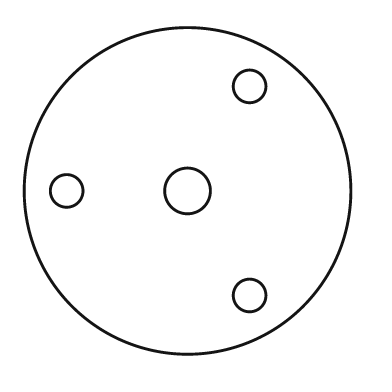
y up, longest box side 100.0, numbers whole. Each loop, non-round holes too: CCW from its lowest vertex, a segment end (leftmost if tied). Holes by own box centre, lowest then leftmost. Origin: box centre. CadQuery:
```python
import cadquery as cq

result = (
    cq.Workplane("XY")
    .moveTo(0.0, 0.0)
    .circle(50.0)
    .moveTo(19.0, -32.0)
    .circle(5.0)
    .moveTo(-37.0, 0.0)
    .circle(5.0)
    .moveTo(0.0, 0.0)
    .circle(7.0)
    .moveTo(19.0, 32.0)
    .circle(5.0)
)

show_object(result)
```